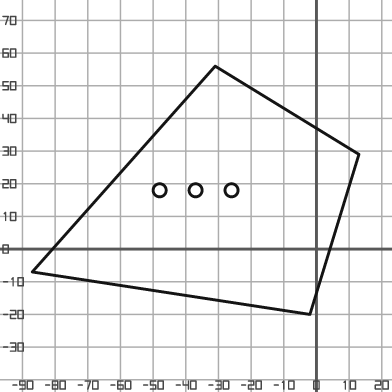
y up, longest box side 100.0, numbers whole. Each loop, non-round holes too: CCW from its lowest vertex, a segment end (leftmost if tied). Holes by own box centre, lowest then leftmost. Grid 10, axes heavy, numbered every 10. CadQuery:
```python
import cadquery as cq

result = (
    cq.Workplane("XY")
    .moveTo(-2.0, -20.0)
    .lineTo(13.0, 29.0)
    .lineTo(-31.0, 56.0)
    .lineTo(-87.0, -7.0)
    .close()
    .moveTo(-48.0, 18.0)
    .circle(2.0)
    .moveTo(-37.0, 18.0)
    .circle(2.0)
    .moveTo(-26.0, 18.0)
    .circle(2.0)
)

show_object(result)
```